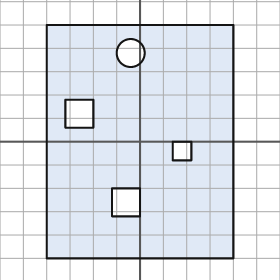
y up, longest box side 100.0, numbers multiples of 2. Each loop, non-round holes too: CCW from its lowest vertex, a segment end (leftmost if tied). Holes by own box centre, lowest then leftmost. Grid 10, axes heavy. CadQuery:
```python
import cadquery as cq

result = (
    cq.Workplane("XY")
    .moveTo(-40.0, -50.0)
    .lineTo(40.0, -50.0)
    .lineTo(40.0, 50.0)
    .lineTo(-40.0, 50.0)
    .close()
    .moveTo(-12.0, -32.0)
    .lineTo(0.0, -32.0)
    .lineTo(0.0, -20.0)
    .lineTo(-12.0, -20.0)
    .close()
    .moveTo(14.0, -8.0)
    .lineTo(22.0, -8.0)
    .lineTo(22.0, 0.0)
    .lineTo(14.0, 0.0)
    .close()
    .moveTo(-32.0, 6.0)
    .lineTo(-20.0, 6.0)
    .lineTo(-20.0, 18.0)
    .lineTo(-32.0, 18.0)
    .close()
    .moveTo(-4.0, 38.0)
    .circle(6.0)
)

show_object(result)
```